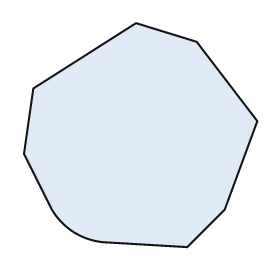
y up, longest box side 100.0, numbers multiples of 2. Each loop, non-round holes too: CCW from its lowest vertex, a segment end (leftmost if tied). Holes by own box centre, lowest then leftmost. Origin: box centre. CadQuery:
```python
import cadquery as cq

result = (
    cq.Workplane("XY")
    .moveTo(20.0, -48.0)
    .lineTo(36.0, -32.0)
    .lineTo(50.0, 6.0)
    .lineTo(24.0, 40.0)
    .lineTo(-2.0, 48.0)
    .lineTo(-46.0, 20.0)
    .lineTo(-50.0, -8.0)
    .lineTo(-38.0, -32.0)
    .threePointArc((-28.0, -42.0), (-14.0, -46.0))
    .close()
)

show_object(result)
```